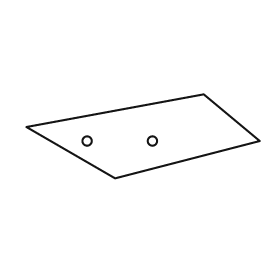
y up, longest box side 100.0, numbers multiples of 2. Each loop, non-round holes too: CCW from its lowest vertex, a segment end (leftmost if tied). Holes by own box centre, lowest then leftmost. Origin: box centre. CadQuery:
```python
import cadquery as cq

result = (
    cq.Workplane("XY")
    .moveTo(-12.0, -18.0)
    .lineTo(50.0, -2.0)
    .lineTo(26.0, 18.0)
    .lineTo(-50.0, 4.0)
    .close()
    .moveTo(-24.0, -2.0)
    .circle(2.0)
    .moveTo(4.0, -2.0)
    .circle(2.0)
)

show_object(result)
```